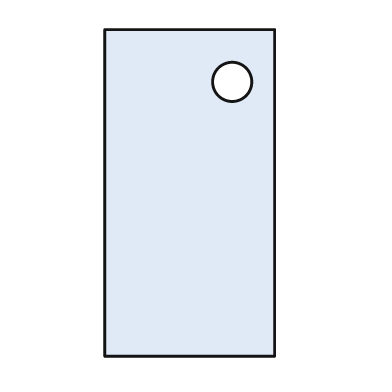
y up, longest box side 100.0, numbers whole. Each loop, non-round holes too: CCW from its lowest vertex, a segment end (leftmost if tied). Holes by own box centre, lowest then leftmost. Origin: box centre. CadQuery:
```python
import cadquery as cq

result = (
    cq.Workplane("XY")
    .moveTo(-26.0, -50.0)
    .lineTo(26.0, -50.0)
    .lineTo(26.0, 50.0)
    .lineTo(-26.0, 50.0)
    .close()
    .moveTo(13.0, 34.0)
    .circle(6.0)
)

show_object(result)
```